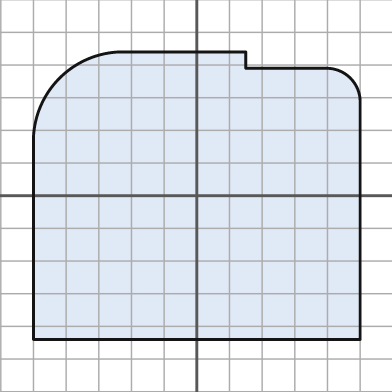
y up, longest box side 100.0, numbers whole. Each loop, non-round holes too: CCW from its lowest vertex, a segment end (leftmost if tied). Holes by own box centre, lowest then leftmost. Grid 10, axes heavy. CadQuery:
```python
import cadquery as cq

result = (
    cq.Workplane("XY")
    .moveTo(-50.0, -44.0)
    .lineTo(50.0, -44.0)
    .lineTo(50.0, 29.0)
    .threePointArc((47.0, 36.0), (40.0, 39.0))
    .lineTo(15.0, 39.0)
    .lineTo(15.0, 44.0)
    .lineTo(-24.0, 44.0)
    .threePointArc((-42.0, 36.0), (-50.0, 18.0))
    .close()
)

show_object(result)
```